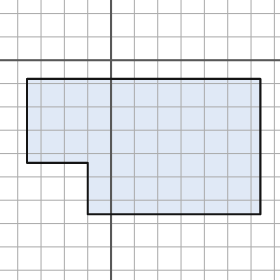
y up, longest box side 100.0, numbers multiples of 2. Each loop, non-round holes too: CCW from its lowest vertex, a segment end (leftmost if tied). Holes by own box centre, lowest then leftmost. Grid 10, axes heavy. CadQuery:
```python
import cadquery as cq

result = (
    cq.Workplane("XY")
    .moveTo(-10.0, -66.0)
    .lineTo(64.0, -66.0)
    .lineTo(64.0, -8.0)
    .lineTo(-36.0, -8.0)
    .lineTo(-36.0, -44.0)
    .lineTo(-10.0, -44.0)
    .close()
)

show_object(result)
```